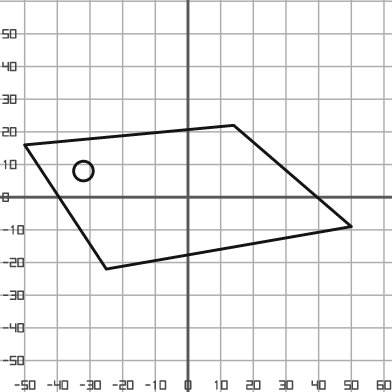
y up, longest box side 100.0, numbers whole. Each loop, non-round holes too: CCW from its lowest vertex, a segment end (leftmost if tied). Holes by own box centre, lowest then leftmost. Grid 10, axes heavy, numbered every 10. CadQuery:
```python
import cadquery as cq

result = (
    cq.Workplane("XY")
    .moveTo(-25.0, -22.0)
    .lineTo(50.0, -9.0)
    .lineTo(14.0, 22.0)
    .lineTo(-50.0, 16.0)
    .close()
    .moveTo(-32.0, 8.0)
    .circle(3.0)
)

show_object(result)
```